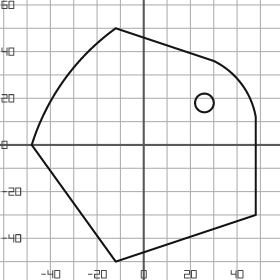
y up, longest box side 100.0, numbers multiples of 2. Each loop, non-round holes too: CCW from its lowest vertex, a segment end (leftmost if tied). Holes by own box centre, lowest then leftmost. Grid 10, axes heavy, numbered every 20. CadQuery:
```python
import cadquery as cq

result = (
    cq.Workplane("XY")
    .moveTo(-12.0, -50.0)
    .lineTo(48.0, -30.0)
    .lineTo(48.0, 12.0)
    .threePointArc((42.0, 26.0), (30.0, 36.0))
    .lineTo(-12.0, 50.0)
    .threePointArc((-34.0, 28.0), (-48.0, 0.0))
    .close()
    .moveTo(26.0, 18.0)
    .circle(4.0)
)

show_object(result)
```